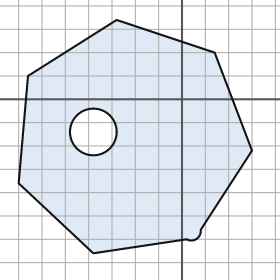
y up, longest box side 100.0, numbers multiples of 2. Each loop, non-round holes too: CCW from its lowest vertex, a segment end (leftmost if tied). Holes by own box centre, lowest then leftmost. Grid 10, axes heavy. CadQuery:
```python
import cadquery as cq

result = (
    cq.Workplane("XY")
    .moveTo(-38.0, -66.0)
    .lineTo(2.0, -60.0)
    .threePointArc((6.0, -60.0), (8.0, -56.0))
    .lineTo(30.0, -22.0)
    .lineTo(14.0, 20.0)
    .lineTo(-28.0, 34.0)
    .lineTo(-66.0, 10.0)
    .lineTo(-70.0, -36.0)
    .close()
    .moveTo(-38.0, -14.0)
    .circle(10.0)
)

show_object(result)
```